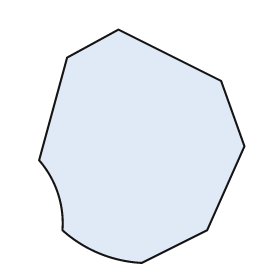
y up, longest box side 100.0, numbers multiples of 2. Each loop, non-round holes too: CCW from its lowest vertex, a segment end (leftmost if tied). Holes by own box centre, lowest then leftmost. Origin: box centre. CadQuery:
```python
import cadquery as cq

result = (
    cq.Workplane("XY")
    .moveTo(0.0, -50.0)
    .lineTo(28.0, -36.0)
    .lineTo(44.0, 0.0)
    .lineTo(34.0, 28.0)
    .lineTo(-10.0, 50.0)
    .lineTo(-32.0, 38.0)
    .lineTo(-44.0, -6.0)
    .threePointArc((-36.0, -20.0), (-34.0, -36.0))
    .threePointArc((-18.0, -46.0), (0.0, -50.0))
    .close()
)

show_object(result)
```